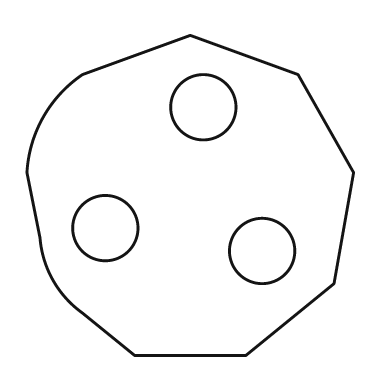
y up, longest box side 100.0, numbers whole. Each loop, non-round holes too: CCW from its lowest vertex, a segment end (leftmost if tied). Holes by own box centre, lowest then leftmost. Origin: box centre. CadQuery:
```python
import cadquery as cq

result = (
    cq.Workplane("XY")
    .moveTo(-17.0, -49.0)
    .lineTo(17.0, -49.0)
    .lineTo(44.0, -27.0)
    .lineTo(50.0, 7.0)
    .lineTo(33.0, 37.0)
    .lineTo(0.0, 49.0)
    .lineTo(-33.0, 37.0)
    .threePointArc((-45.0, 24.0), (-50.0, 7.0))
    .lineTo(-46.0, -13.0)
    .threePointArc((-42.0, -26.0), (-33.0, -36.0))
    .close()
    .moveTo(22.0, -17.0)
    .circle(10.0)
    .moveTo(-26.0, -10.0)
    .circle(10.0)
    .moveTo(4.0, 27.0)
    .circle(10.0)
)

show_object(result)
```